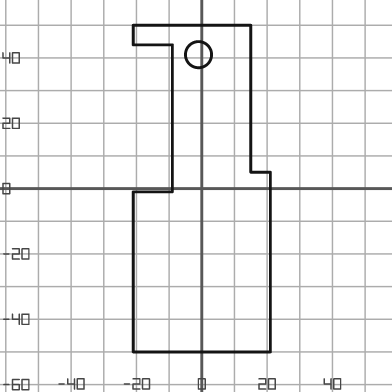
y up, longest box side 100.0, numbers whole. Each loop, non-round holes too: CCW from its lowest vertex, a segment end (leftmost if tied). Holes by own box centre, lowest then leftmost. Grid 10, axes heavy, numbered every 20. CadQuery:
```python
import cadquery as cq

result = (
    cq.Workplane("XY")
    .moveTo(-21.0, -50.0)
    .lineTo(21.0, -50.0)
    .lineTo(21.0, 5.0)
    .lineTo(15.0, 5.0)
    .lineTo(15.0, 50.0)
    .lineTo(-21.0, 50.0)
    .lineTo(-21.0, 44.0)
    .lineTo(-9.0, 44.0)
    .lineTo(-9.0, -1.0)
    .lineTo(-21.0, -1.0)
    .close()
    .moveTo(-1.0, 41.0)
    .circle(4.0)
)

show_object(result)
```